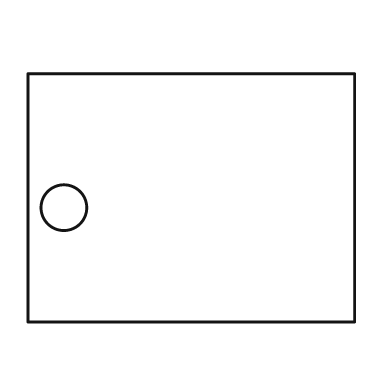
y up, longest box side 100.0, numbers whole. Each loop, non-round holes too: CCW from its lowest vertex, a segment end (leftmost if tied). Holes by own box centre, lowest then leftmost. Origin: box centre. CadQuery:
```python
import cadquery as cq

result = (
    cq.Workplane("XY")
    .moveTo(-50.0, -38.0)
    .lineTo(50.0, -38.0)
    .lineTo(50.0, 38.0)
    .lineTo(-50.0, 38.0)
    .close()
    .moveTo(-39.0, -3.0)
    .circle(7.0)
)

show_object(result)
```